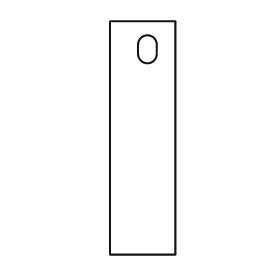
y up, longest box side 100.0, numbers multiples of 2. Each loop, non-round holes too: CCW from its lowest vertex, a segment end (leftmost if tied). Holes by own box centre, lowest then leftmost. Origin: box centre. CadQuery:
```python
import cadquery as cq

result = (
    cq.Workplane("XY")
    .moveTo(-14.0, -50.0)
    .lineTo(14.0, -50.0)
    .lineTo(14.0, 50.0)
    .lineTo(-14.0, 50.0)
    .close()
    .moveTo(-2.0, 36.0)
    .threePointArc((2.0, 32.0), (6.0, 36.0))
    .lineTo(6.0, 40.0)
    .threePointArc((2.0, 44.0), (-2.0, 40.0))
    .close()
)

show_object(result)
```